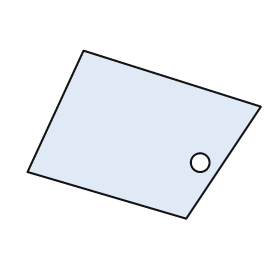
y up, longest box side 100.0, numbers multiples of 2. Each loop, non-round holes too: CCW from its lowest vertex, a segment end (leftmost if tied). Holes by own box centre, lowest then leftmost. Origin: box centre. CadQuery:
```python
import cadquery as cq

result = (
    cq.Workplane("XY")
    .moveTo(18.0, -36.0)
    .lineTo(50.0, 12.0)
    .lineTo(-26.0, 36.0)
    .lineTo(-50.0, -16.0)
    .close()
    .moveTo(24.0, -12.0)
    .circle(4.0)
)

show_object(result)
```